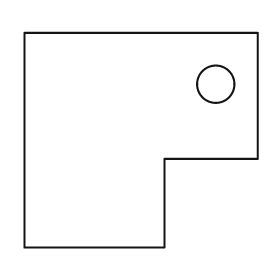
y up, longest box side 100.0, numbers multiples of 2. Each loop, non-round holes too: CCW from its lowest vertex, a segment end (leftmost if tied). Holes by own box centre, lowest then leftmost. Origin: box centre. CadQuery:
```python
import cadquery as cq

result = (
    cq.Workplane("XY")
    .moveTo(-50.0, -46.0)
    .lineTo(10.0, -46.0)
    .lineTo(10.0, -8.0)
    .lineTo(50.0, -8.0)
    .lineTo(50.0, 46.0)
    .lineTo(-50.0, 46.0)
    .close()
    .moveTo(32.0, 24.0)
    .circle(8.0)
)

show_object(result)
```